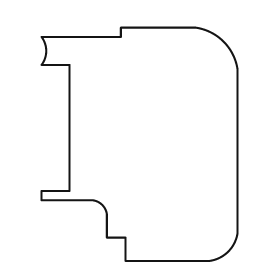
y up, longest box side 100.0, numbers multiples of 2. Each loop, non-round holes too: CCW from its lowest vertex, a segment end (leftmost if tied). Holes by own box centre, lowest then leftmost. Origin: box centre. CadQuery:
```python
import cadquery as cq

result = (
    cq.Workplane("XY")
    .moveTo(-6.0, -50.0)
    .lineTo(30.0, -50.0)
    .threePointArc((38.0, -46.0), (42.0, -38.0))
    .lineTo(42.0, 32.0)
    .threePointArc((36.0, 44.0), (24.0, 50.0))
    .lineTo(-8.0, 50.0)
    .lineTo(-8.0, 46.0)
    .lineTo(-42.0, 46.0)
    .threePointArc((-40.0, 40.0), (-42.0, 34.0))
    .lineTo(-30.0, 34.0)
    .lineTo(-30.0, -20.0)
    .lineTo(-42.0, -20.0)
    .lineTo(-42.0, -24.0)
    .lineTo(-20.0, -24.0)
    .threePointArc((-16.0, -26.0), (-14.0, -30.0))
    .lineTo(-14.0, -40.0)
    .lineTo(-6.0, -40.0)
    .close()
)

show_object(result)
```